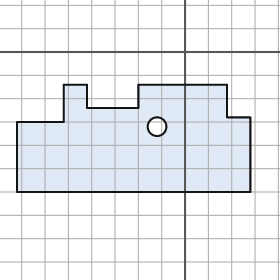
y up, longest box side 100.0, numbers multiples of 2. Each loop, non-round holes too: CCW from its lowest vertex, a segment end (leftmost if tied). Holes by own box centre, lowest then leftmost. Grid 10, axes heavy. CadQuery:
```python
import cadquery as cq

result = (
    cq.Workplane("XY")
    .moveTo(-72.0, -60.0)
    .lineTo(28.0, -60.0)
    .lineTo(28.0, -28.0)
    .lineTo(18.0, -28.0)
    .lineTo(18.0, -14.0)
    .lineTo(-20.0, -14.0)
    .lineTo(-20.0, -24.0)
    .lineTo(-42.0, -24.0)
    .lineTo(-42.0, -14.0)
    .lineTo(-52.0, -14.0)
    .lineTo(-52.0, -30.0)
    .lineTo(-72.0, -30.0)
    .close()
    .moveTo(-12.0, -32.0)
    .circle(4.0)
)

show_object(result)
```